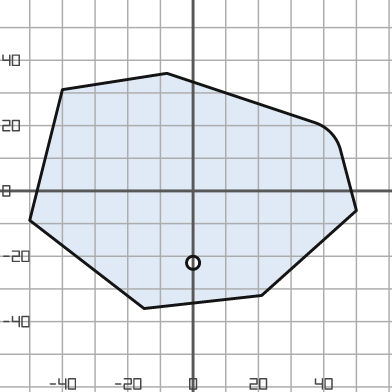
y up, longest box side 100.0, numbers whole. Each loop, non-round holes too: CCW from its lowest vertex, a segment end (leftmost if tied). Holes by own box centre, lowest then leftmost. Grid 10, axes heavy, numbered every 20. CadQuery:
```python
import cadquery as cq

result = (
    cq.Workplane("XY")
    .moveTo(-15.0, -36.0)
    .lineTo(21.0, -32.0)
    .lineTo(50.0, -6.0)
    .lineTo(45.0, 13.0)
    .threePointArc((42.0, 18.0), (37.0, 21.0))
    .lineTo(-8.0, 36.0)
    .lineTo(-40.0, 31.0)
    .lineTo(-50.0, -9.0)
    .close()
    .moveTo(0.0, -22.0)
    .circle(2.0)
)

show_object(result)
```